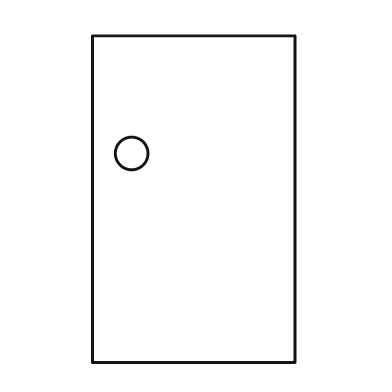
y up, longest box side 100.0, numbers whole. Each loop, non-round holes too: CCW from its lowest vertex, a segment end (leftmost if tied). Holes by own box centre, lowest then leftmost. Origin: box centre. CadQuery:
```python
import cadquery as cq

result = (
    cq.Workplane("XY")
    .moveTo(-31.0, -50.0)
    .lineTo(31.0, -50.0)
    .lineTo(31.0, 50.0)
    .lineTo(-31.0, 50.0)
    .close()
    .moveTo(-19.0, 14.0)
    .circle(5.0)
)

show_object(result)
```